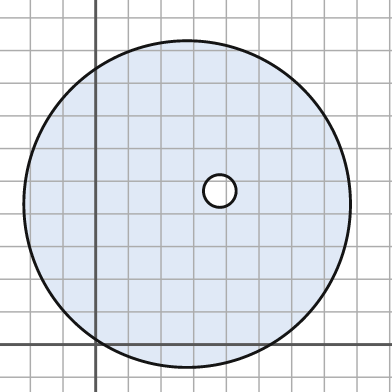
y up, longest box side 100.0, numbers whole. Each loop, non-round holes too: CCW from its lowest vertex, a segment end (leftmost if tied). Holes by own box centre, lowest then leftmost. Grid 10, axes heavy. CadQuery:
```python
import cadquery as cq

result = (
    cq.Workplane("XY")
    .moveTo(28.0, 43.0)
    .circle(50.0)
    .moveTo(38.0, 47.0)
    .circle(5.0)
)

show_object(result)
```